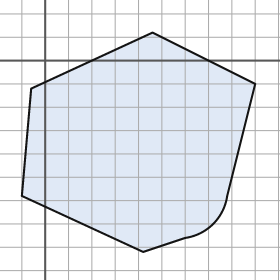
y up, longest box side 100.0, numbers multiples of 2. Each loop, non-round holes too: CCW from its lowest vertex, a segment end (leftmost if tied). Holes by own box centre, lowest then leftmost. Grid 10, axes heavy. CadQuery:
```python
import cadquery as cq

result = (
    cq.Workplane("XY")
    .moveTo(42.0, -82.0)
    .lineTo(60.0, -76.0)
    .threePointArc((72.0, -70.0), (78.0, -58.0))
    .lineTo(90.0, -10.0)
    .lineTo(46.0, 12.0)
    .lineTo(-6.0, -12.0)
    .lineTo(-10.0, -58.0)
    .close()
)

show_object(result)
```